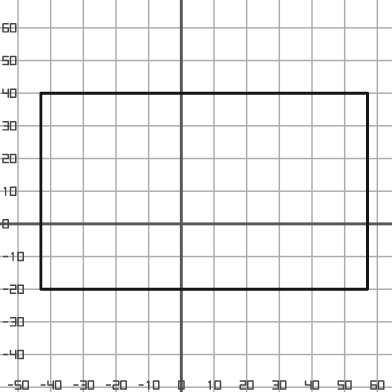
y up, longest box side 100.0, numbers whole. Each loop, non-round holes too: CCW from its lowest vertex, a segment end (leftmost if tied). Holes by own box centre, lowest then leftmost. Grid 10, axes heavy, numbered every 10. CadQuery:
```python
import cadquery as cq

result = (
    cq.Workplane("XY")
    .moveTo(-43.0, -20.0)
    .lineTo(57.0, -20.0)
    .lineTo(57.0, 40.0)
    .lineTo(-43.0, 40.0)
    .close()
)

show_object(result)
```